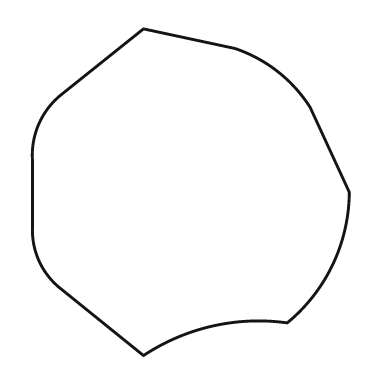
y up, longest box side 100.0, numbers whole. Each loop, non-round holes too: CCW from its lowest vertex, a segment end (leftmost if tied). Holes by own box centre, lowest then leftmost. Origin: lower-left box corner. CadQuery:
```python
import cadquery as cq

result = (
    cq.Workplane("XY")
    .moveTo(34.0, 0.0)
    .threePointArc((55.0, 9.0), (78.0, 10.0))
    .threePointArc((92.0, 28.0), (97.0, 50.0))
    .lineTo(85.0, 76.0)
    .threePointArc((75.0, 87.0), (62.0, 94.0))
    .lineTo(34.0, 100.0)
    .lineTo(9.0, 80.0)
    .threePointArc((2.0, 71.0), (0.0, 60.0))
    .lineTo(0.0, 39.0)
    .threePointArc((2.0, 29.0), (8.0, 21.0))
    .close()
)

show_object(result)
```